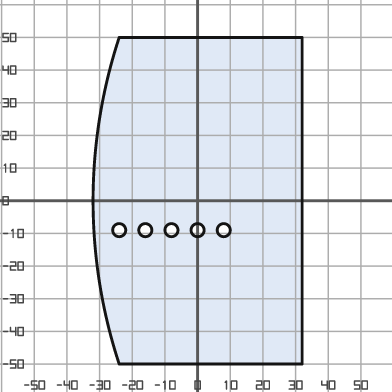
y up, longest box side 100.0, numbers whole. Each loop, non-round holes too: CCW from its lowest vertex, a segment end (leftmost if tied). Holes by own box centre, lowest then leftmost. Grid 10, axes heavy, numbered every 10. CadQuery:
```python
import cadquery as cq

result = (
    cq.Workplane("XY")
    .moveTo(-24.0, -50.0)
    .lineTo(32.0, -50.0)
    .lineTo(32.0, 50.0)
    .lineTo(-24.0, 50.0)
    .threePointArc((-32.0, 0.0), (-24.0, -50.0))
    .close()
    .moveTo(-24.0, -9.0)
    .circle(2.0)
    .moveTo(-16.0, -9.0)
    .circle(2.0)
    .moveTo(-8.0, -9.0)
    .circle(2.0)
    .moveTo(0.0, -9.0)
    .circle(2.0)
    .moveTo(8.0, -9.0)
    .circle(2.0)
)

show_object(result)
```